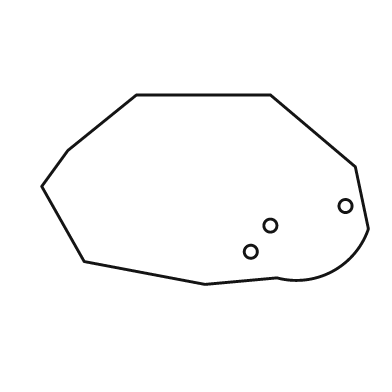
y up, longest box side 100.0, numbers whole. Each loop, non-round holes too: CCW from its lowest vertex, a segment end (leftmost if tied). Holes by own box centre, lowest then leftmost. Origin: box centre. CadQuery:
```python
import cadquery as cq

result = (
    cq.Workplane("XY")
    .moveTo(0.0, -29.0)
    .lineTo(22.0, -27.0)
    .threePointArc((39.0, -25.0), (50.0, -12.0))
    .lineTo(46.0, 7.0)
    .lineTo(20.0, 29.0)
    .lineTo(-21.0, 29.0)
    .lineTo(-42.0, 12.0)
    .lineTo(-50.0, 1.0)
    .lineTo(-37.0, -22.0)
    .close()
    .moveTo(14.0, -19.0)
    .circle(2.0)
    .moveTo(20.0, -11.0)
    .circle(2.0)
    .moveTo(43.0, -5.0)
    .circle(2.0)
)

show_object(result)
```